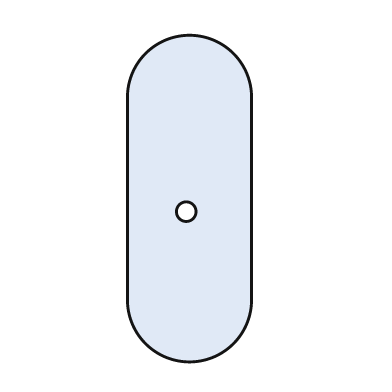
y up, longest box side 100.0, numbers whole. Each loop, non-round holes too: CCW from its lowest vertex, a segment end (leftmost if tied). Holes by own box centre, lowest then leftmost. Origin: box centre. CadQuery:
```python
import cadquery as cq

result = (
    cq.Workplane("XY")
    .moveTo(-19.0, -31.0)
    .threePointArc((0.0, -50.0), (19.0, -31.0))
    .lineTo(19.0, 31.0)
    .threePointArc((0.0, 50.0), (-19.0, 31.0))
    .close()
    .moveTo(-1.0, -4.0)
    .circle(3.0)
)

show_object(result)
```